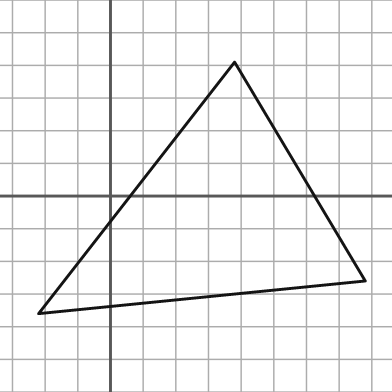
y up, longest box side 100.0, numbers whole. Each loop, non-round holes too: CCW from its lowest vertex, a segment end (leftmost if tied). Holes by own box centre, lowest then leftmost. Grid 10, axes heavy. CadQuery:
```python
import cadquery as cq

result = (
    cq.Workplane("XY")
    .moveTo(-22.0, -36.0)
    .lineTo(78.0, -26.0)
    .lineTo(38.0, 41.0)
    .close()
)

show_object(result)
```